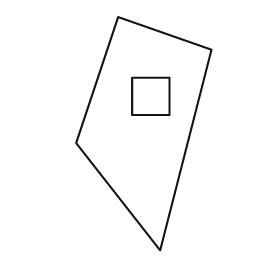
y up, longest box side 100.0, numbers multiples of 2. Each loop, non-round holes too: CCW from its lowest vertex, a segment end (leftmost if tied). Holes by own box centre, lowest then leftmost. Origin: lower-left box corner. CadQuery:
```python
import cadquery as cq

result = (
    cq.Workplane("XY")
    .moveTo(36.0, 0.0)
    .lineTo(58.0, 86.0)
    .lineTo(18.0, 100.0)
    .lineTo(0.0, 46.0)
    .close()
    .moveTo(24.0, 58.0)
    .lineTo(40.0, 58.0)
    .lineTo(40.0, 74.0)
    .lineTo(24.0, 74.0)
    .close()
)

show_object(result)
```